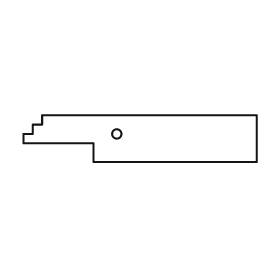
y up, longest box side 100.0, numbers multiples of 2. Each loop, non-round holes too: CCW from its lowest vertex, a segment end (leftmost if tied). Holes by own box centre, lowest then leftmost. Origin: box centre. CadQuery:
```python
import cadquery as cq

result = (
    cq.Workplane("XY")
    .moveTo(-20.0, -10.0)
    .lineTo(50.0, -10.0)
    .lineTo(50.0, 10.0)
    .lineTo(-42.0, 10.0)
    .lineTo(-42.0, 6.0)
    .lineTo(-46.0, 6.0)
    .lineTo(-46.0, 2.0)
    .lineTo(-50.0, 2.0)
    .lineTo(-50.0, -2.0)
    .lineTo(-20.0, -2.0)
    .close()
    .moveTo(-10.0, 2.0)
    .circle(2.0)
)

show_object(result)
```